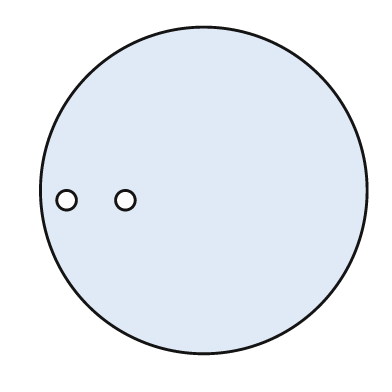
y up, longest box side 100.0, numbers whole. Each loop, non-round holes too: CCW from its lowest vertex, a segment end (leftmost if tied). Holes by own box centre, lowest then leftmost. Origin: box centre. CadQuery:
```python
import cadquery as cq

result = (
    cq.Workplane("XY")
    .moveTo(0.0, 0.0)
    .circle(50.0)
    .moveTo(-42.0, -3.0)
    .circle(3.0)
    .moveTo(-24.0, -3.0)
    .circle(3.0)
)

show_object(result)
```